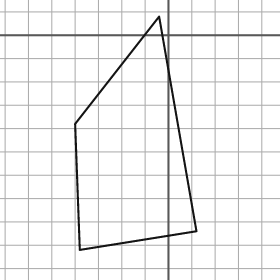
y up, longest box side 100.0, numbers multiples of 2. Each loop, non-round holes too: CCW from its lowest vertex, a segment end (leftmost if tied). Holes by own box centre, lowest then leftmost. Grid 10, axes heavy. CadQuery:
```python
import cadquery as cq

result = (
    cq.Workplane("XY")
    .moveTo(-38.0, -92.0)
    .lineTo(12.0, -84.0)
    .lineTo(-4.0, 8.0)
    .lineTo(-40.0, -38.0)
    .close()
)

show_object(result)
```